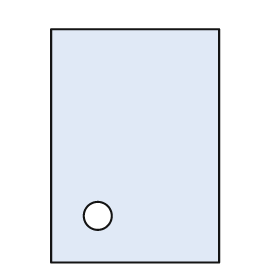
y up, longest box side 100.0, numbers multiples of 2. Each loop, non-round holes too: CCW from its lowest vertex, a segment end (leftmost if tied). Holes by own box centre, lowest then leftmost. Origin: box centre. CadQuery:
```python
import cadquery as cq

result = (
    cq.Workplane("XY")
    .moveTo(-36.0, -50.0)
    .lineTo(36.0, -50.0)
    .lineTo(36.0, 50.0)
    .lineTo(-36.0, 50.0)
    .close()
    .moveTo(-16.0, -30.0)
    .circle(6.0)
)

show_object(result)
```